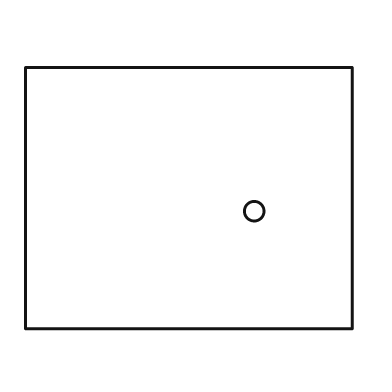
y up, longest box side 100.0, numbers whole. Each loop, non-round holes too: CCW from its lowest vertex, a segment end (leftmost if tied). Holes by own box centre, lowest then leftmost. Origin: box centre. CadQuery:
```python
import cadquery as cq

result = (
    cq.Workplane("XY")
    .moveTo(-50.0, -40.0)
    .lineTo(50.0, -40.0)
    .lineTo(50.0, 40.0)
    .lineTo(-50.0, 40.0)
    .close()
    .moveTo(20.0, -4.0)
    .circle(3.0)
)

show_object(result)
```